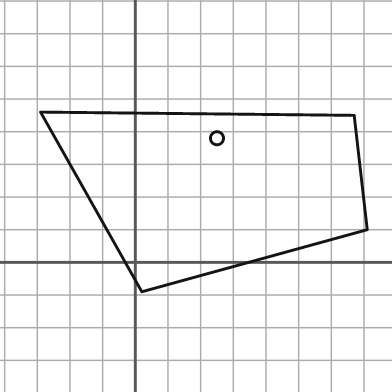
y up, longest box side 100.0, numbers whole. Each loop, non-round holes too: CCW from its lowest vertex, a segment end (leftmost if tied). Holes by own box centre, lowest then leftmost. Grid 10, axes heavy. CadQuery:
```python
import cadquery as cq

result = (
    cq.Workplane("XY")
    .moveTo(2.0, -9.0)
    .lineTo(71.0, 10.0)
    .lineTo(67.0, 45.0)
    .lineTo(-29.0, 46.0)
    .close()
    .moveTo(25.0, 38.0)
    .circle(2.0)
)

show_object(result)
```